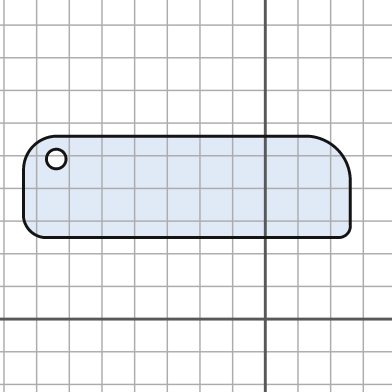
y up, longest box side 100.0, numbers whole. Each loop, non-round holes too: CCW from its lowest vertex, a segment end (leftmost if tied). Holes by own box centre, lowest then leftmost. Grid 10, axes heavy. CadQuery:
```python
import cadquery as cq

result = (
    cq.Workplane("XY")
    .moveTo(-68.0, 25.0)
    .lineTo(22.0, 25.0)
    .threePointArc((25.0, 26.0), (26.0, 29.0))
    .lineTo(26.0, 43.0)
    .threePointArc((22.0, 52.0), (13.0, 56.0))
    .lineTo(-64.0, 56.0)
    .threePointArc((-71.0, 53.0), (-74.0, 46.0))
    .lineTo(-74.0, 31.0)
    .threePointArc((-72.0, 27.0), (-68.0, 25.0))
    .close()
    .moveTo(-64.0, 49.0)
    .circle(3.0)
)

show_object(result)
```